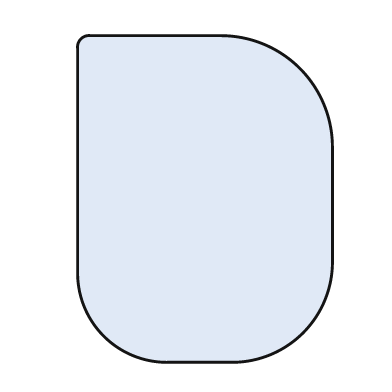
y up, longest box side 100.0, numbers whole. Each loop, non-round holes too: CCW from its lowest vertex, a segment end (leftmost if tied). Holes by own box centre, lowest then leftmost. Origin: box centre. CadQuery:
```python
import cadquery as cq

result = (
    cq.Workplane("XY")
    .moveTo(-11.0, -50.0)
    .lineTo(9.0, -50.0)
    .threePointArc((30.0, -41.0), (39.0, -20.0))
    .lineTo(39.0, 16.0)
    .threePointArc((29.0, 40.0), (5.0, 50.0))
    .lineTo(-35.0, 50.0)
    .threePointArc((-38.0, 49.0), (-39.0, 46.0))
    .lineTo(-39.0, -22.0)
    .threePointArc((-31.0, -42.0), (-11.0, -50.0))
    .close()
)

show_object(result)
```